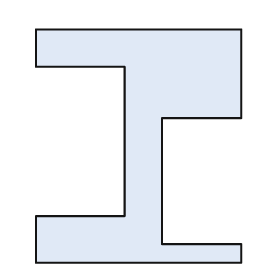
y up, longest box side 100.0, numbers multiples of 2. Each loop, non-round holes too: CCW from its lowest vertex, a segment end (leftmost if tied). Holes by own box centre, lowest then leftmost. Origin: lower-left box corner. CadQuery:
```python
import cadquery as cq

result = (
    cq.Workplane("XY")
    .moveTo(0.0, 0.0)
    .lineTo(88.0, 0.0)
    .lineTo(88.0, 8.0)
    .lineTo(54.0, 8.0)
    .lineTo(54.0, 62.0)
    .lineTo(88.0, 62.0)
    .lineTo(88.0, 100.0)
    .lineTo(0.0, 100.0)
    .lineTo(0.0, 84.0)
    .lineTo(38.0, 84.0)
    .lineTo(38.0, 20.0)
    .lineTo(0.0, 20.0)
    .close()
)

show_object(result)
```